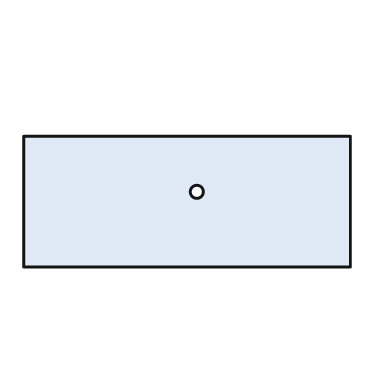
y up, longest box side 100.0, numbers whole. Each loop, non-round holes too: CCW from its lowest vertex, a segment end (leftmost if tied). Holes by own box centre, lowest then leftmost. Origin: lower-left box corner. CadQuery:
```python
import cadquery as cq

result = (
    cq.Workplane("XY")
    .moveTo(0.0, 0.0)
    .lineTo(100.0, 0.0)
    .lineTo(100.0, 40.0)
    .lineTo(0.0, 40.0)
    .close()
    .moveTo(53.0, 23.0)
    .circle(2.0)
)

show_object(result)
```